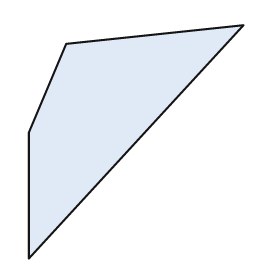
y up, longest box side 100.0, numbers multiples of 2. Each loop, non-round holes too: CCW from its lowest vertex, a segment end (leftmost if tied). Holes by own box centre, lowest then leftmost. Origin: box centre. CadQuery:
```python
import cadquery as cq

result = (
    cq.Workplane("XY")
    .moveTo(-46.0, -50.0)
    .lineTo(46.0, 50.0)
    .lineTo(-30.0, 42.0)
    .lineTo(-46.0, 4.0)
    .close()
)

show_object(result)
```